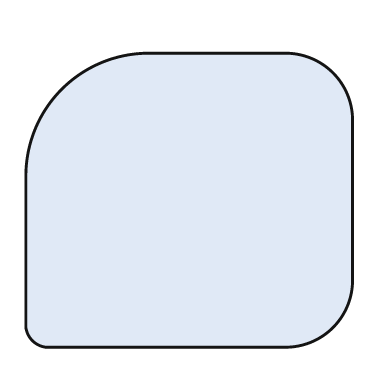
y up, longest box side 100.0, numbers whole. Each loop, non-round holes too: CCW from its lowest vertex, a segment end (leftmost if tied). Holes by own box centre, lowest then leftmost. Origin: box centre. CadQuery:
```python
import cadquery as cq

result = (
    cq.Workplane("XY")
    .moveTo(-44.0, -45.0)
    .lineTo(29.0, -45.0)
    .threePointArc((44.0, -39.0), (50.0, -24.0))
    .lineTo(50.0, 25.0)
    .threePointArc((44.0, 39.0), (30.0, 45.0))
    .lineTo(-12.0, 45.0)
    .threePointArc((-39.0, 34.0), (-50.0, 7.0))
    .lineTo(-50.0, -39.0)
    .threePointArc((-48.0, -43.0), (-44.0, -45.0))
    .close()
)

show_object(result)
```